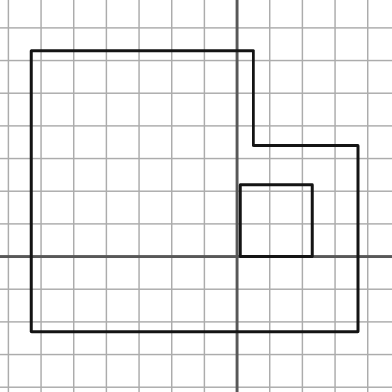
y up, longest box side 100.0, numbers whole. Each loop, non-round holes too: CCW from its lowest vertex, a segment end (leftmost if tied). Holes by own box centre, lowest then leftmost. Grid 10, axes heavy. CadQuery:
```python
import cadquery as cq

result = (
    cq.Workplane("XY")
    .moveTo(-63.0, -23.0)
    .lineTo(37.0, -23.0)
    .lineTo(37.0, 34.0)
    .lineTo(5.0, 34.0)
    .lineTo(5.0, 63.0)
    .lineTo(-63.0, 63.0)
    .close()
    .moveTo(1.0, 0.0)
    .lineTo(23.0, 0.0)
    .lineTo(23.0, 22.0)
    .lineTo(1.0, 22.0)
    .close()
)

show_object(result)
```